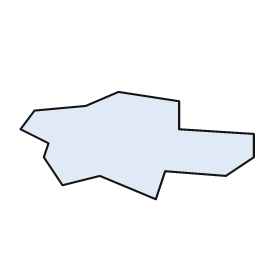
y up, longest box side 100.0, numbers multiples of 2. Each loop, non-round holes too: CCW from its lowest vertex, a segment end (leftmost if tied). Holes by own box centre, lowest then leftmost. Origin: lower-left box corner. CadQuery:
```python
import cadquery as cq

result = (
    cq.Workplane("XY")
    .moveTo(58.0, 0.0)
    .lineTo(62.0, 12.0)
    .lineTo(88.0, 10.0)
    .lineTo(100.0, 18.0)
    .lineTo(100.0, 28.0)
    .lineTo(68.0, 30.0)
    .lineTo(68.0, 42.0)
    .lineTo(42.0, 46.0)
    .lineTo(28.0, 40.0)
    .lineTo(6.0, 38.0)
    .lineTo(0.0, 30.0)
    .lineTo(12.0, 24.0)
    .lineTo(10.0, 18.0)
    .lineTo(18.0, 6.0)
    .lineTo(34.0, 10.0)
    .close()
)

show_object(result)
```